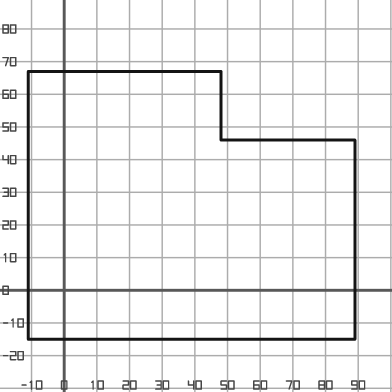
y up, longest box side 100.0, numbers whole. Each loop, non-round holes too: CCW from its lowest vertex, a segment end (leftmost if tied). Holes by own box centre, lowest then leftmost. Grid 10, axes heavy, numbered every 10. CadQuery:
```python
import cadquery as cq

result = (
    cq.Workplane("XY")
    .moveTo(-11.0, -15.0)
    .lineTo(89.0, -15.0)
    .lineTo(89.0, 46.0)
    .lineTo(48.0, 46.0)
    .lineTo(48.0, 67.0)
    .lineTo(-11.0, 67.0)
    .close()
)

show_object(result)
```